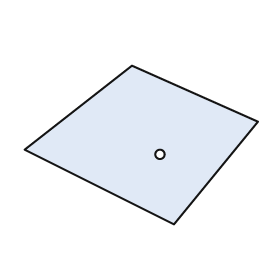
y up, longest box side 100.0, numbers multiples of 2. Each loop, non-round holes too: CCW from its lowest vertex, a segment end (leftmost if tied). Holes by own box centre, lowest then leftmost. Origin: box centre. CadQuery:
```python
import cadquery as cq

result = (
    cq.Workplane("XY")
    .moveTo(14.0, -34.0)
    .lineTo(50.0, 10.0)
    .lineTo(-4.0, 34.0)
    .lineTo(-50.0, -2.0)
    .close()
    .moveTo(8.0, -4.0)
    .circle(2.0)
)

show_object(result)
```